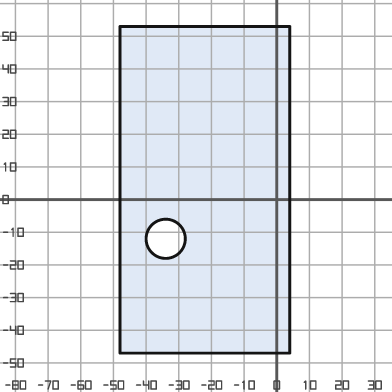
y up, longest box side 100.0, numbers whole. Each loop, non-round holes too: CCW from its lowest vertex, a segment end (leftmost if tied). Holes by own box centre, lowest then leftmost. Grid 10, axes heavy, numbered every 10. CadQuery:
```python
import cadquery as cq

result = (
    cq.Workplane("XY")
    .moveTo(-48.0, -47.0)
    .lineTo(4.0, -47.0)
    .lineTo(4.0, 53.0)
    .lineTo(-48.0, 53.0)
    .close()
    .moveTo(-34.0, -12.0)
    .circle(6.0)
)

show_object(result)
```